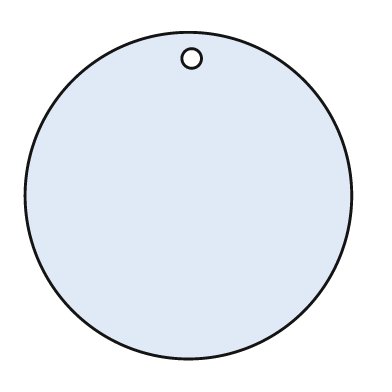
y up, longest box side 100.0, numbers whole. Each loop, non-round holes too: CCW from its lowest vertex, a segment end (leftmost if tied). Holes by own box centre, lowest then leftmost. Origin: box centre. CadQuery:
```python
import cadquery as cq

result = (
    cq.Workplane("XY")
    .moveTo(0.0, 0.0)
    .circle(50.0)
    .moveTo(1.0, 42.0)
    .circle(3.0)
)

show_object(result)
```